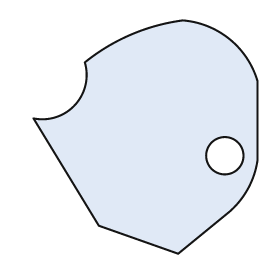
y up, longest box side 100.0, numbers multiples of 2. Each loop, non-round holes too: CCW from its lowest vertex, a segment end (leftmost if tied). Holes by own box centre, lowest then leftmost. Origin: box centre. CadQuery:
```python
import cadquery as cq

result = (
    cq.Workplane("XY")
    .moveTo(14.0, -50.0)
    .lineTo(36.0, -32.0)
    .threePointArc((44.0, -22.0), (48.0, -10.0))
    .lineTo(48.0, 24.0)
    .threePointArc((36.0, 42.0), (16.0, 50.0))
    .threePointArc((-6.0, 44.0), (-26.0, 32.0))
    .threePointArc((-30.0, 14.0), (-48.0, 8.0))
    .lineTo(-20.0, -38.0)
    .close()
    .moveTo(34.0, -8.0)
    .circle(8.0)
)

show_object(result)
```